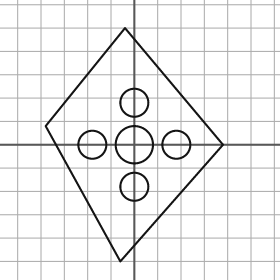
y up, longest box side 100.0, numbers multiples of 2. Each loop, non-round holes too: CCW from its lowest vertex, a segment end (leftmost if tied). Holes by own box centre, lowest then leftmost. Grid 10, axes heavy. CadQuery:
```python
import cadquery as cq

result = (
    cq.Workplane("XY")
    .moveTo(-6.0, -50.0)
    .lineTo(38.0, 0.0)
    .lineTo(-4.0, 50.0)
    .lineTo(-38.0, 8.0)
    .close()
    .moveTo(0.0, -18.0)
    .circle(6.0)
    .moveTo(-18.0, 0.0)
    .circle(6.0)
    .moveTo(0.0, 0.0)
    .circle(8.0)
    .moveTo(18.0, 0.0)
    .circle(6.0)
    .moveTo(0.0, 18.0)
    .circle(6.0)
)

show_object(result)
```